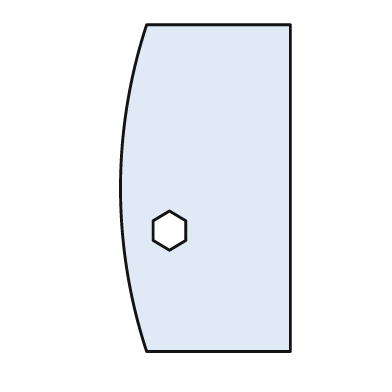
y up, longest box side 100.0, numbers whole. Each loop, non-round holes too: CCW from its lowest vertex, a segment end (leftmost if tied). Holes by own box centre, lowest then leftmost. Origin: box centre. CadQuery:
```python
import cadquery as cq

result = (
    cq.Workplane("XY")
    .moveTo(-18.0, -50.0)
    .lineTo(26.0, -50.0)
    .lineTo(26.0, 50.0)
    .lineTo(-18.0, 50.0)
    .threePointArc((-26.0, 0.0), (-18.0, -50.0))
    .close()
    .moveTo(-11.0, -19.0)
    .lineTo(-6.0, -16.0)
    .lineTo(-6.0, -10.0)
    .lineTo(-11.0, -7.0)
    .lineTo(-16.0, -10.0)
    .lineTo(-16.0, -16.0)
    .close()
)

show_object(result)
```